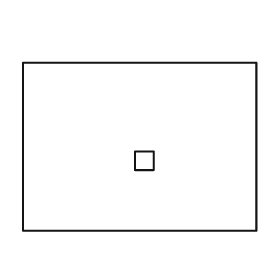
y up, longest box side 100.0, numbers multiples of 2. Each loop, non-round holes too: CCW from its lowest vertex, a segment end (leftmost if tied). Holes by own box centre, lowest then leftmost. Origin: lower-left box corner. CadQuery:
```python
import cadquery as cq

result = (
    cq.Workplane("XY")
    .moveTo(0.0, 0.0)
    .lineTo(100.0, 0.0)
    .lineTo(100.0, 72.0)
    .lineTo(0.0, 72.0)
    .close()
    .moveTo(48.0, 26.0)
    .lineTo(56.0, 26.0)
    .lineTo(56.0, 34.0)
    .lineTo(48.0, 34.0)
    .close()
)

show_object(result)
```